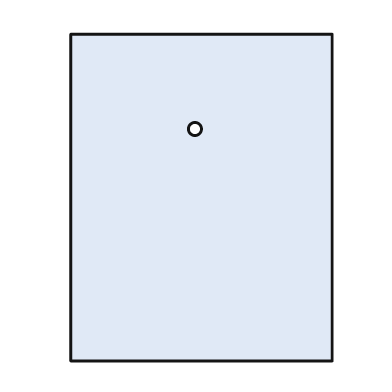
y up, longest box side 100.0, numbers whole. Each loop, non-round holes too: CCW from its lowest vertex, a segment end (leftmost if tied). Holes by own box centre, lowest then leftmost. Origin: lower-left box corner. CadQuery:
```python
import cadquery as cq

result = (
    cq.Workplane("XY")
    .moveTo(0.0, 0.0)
    .lineTo(80.0, 0.0)
    .lineTo(80.0, 100.0)
    .lineTo(0.0, 100.0)
    .close()
    .moveTo(38.0, 71.0)
    .circle(2.0)
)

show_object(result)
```